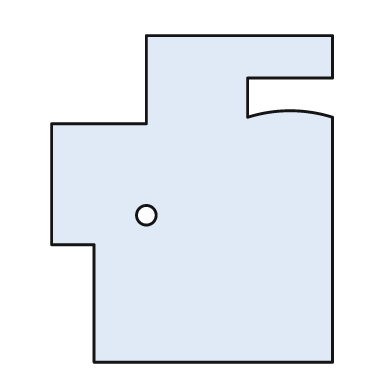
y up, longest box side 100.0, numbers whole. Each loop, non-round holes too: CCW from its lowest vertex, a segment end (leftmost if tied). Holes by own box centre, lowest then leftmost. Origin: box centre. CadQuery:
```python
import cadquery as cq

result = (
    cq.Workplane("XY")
    .moveTo(-30.0, -50.0)
    .lineTo(43.0, -50.0)
    .lineTo(43.0, 25.0)
    .threePointArc((30.0, 27.0), (17.0, 25.0))
    .lineTo(17.0, 37.0)
    .lineTo(43.0, 37.0)
    .lineTo(43.0, 50.0)
    .lineTo(-14.0, 50.0)
    .lineTo(-14.0, 23.0)
    .lineTo(-43.0, 23.0)
    .lineTo(-43.0, -14.0)
    .lineTo(-30.0, -14.0)
    .close()
    .moveTo(-14.0, -5.0)
    .circle(3.0)
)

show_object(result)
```